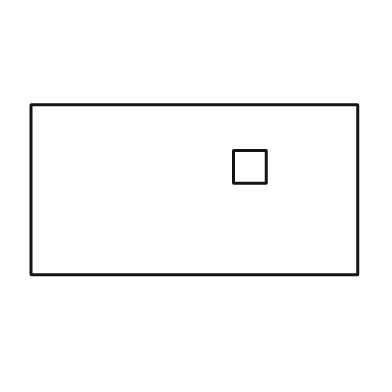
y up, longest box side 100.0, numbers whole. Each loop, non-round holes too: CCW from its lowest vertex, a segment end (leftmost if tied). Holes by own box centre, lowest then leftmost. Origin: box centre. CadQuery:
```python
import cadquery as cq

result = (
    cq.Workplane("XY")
    .moveTo(-50.0, -26.0)
    .lineTo(50.0, -26.0)
    .lineTo(50.0, 26.0)
    .lineTo(-50.0, 26.0)
    .close()
    .moveTo(12.0, 2.0)
    .lineTo(22.0, 2.0)
    .lineTo(22.0, 12.0)
    .lineTo(12.0, 12.0)
    .close()
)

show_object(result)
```